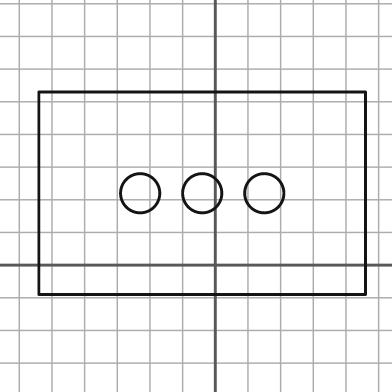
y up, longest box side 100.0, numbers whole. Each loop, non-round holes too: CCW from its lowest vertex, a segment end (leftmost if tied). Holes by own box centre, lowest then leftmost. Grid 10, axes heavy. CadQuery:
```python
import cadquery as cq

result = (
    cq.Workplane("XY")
    .moveTo(-54.0, -9.0)
    .lineTo(46.0, -9.0)
    .lineTo(46.0, 53.0)
    .lineTo(-54.0, 53.0)
    .close()
    .moveTo(-23.0, 22.0)
    .circle(6.0)
    .moveTo(-4.0, 22.0)
    .circle(6.0)
    .moveTo(15.0, 22.0)
    .circle(6.0)
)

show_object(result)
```